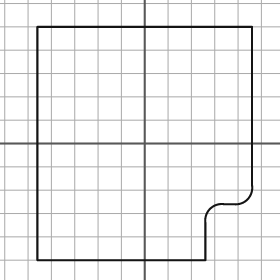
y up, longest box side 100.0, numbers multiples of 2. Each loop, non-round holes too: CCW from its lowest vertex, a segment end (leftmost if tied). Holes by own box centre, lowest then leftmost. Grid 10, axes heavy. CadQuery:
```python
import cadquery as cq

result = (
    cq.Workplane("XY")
    .moveTo(-46.0, -50.0)
    .lineTo(26.0, -50.0)
    .lineTo(26.0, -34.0)
    .threePointArc((28.0, -28.0), (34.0, -26.0))
    .lineTo(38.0, -26.0)
    .threePointArc((44.0, -24.0), (46.0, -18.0))
    .lineTo(46.0, 50.0)
    .lineTo(-46.0, 50.0)
    .close()
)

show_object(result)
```